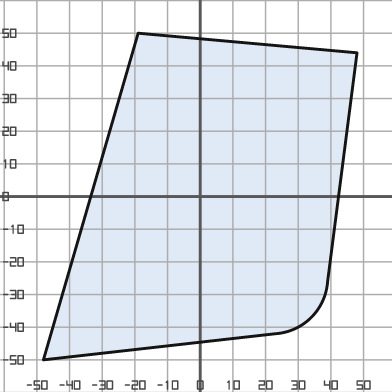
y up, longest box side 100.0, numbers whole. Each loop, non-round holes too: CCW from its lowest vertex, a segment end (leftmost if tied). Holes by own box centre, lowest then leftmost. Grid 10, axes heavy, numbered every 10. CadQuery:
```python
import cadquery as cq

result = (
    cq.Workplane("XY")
    .moveTo(-48.0, -50.0)
    .lineTo(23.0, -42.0)
    .threePointArc((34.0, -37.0), (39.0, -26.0))
    .lineTo(48.0, 44.0)
    .lineTo(-19.0, 50.0)
    .close()
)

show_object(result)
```